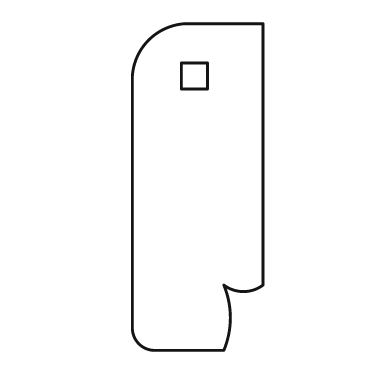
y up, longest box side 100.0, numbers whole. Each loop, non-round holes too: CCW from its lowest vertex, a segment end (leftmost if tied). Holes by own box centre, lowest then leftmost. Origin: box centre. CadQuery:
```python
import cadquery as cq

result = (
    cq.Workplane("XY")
    .moveTo(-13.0, -50.0)
    .lineTo(8.0, -50.0)
    .threePointArc((10.0, -40.0), (8.0, -30.0))
    .threePointArc((14.0, -32.0), (20.0, -30.0))
    .lineTo(20.0, 50.0)
    .lineTo(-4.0, 50.0)
    .threePointArc((-15.0, 45.0), (-20.0, 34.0))
    .lineTo(-20.0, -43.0)
    .threePointArc((-18.0, -48.0), (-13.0, -50.0))
    .close()
    .moveTo(-5.0, 30.0)
    .lineTo(3.0, 30.0)
    .lineTo(3.0, 38.0)
    .lineTo(-5.0, 38.0)
    .close()
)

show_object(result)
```